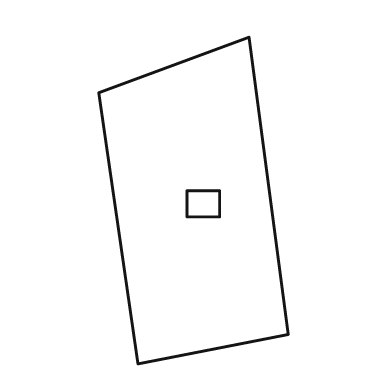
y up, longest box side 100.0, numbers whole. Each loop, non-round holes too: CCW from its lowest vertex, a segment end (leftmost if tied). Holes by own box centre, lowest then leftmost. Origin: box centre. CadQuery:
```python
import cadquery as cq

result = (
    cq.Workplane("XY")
    .moveTo(-17.0, -50.0)
    .lineTo(29.0, -41.0)
    .lineTo(17.0, 50.0)
    .lineTo(-29.0, 33.0)
    .close()
    .moveTo(-2.0, -5.0)
    .lineTo(8.0, -5.0)
    .lineTo(8.0, 3.0)
    .lineTo(-2.0, 3.0)
    .close()
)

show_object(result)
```